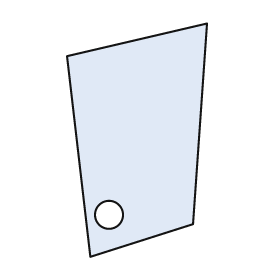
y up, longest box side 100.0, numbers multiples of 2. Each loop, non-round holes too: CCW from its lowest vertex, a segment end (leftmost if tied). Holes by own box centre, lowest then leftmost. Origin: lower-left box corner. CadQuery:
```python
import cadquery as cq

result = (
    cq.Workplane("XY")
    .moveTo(10.0, 0.0)
    .lineTo(54.0, 14.0)
    .lineTo(60.0, 100.0)
    .lineTo(0.0, 86.0)
    .close()
    .moveTo(18.0, 18.0)
    .circle(6.0)
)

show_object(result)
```